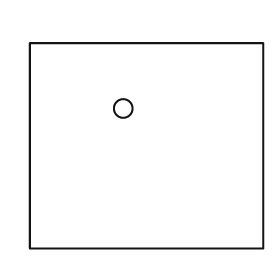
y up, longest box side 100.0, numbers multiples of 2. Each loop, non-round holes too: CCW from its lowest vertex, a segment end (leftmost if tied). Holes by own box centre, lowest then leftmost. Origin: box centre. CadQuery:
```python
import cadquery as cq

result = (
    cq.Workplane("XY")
    .moveTo(-50.0, -44.0)
    .lineTo(50.0, -44.0)
    .lineTo(50.0, 44.0)
    .lineTo(-50.0, 44.0)
    .close()
    .moveTo(-10.0, 16.0)
    .circle(4.0)
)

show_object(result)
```